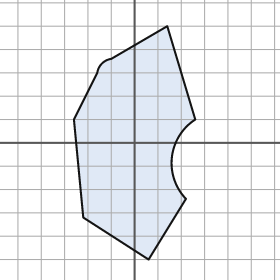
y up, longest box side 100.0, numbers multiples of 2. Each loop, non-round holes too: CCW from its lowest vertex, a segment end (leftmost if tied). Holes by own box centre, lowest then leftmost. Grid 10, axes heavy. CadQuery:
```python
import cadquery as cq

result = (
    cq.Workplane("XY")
    .moveTo(6.0, -50.0)
    .lineTo(22.0, -24.0)
    .threePointArc((16.0, -6.0), (26.0, 10.0))
    .lineTo(14.0, 50.0)
    .lineTo(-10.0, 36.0)
    .threePointArc((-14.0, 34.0), (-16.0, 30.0))
    .lineTo(-26.0, 10.0)
    .lineTo(-22.0, -32.0)
    .close()
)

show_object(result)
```